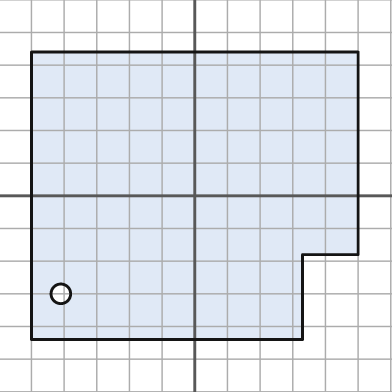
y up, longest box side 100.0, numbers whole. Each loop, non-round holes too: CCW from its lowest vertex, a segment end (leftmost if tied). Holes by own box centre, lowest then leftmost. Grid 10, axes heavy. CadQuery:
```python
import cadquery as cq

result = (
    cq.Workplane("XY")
    .moveTo(-50.0, -44.0)
    .lineTo(33.0, -44.0)
    .lineTo(33.0, -18.0)
    .lineTo(50.0, -18.0)
    .lineTo(50.0, 44.0)
    .lineTo(-50.0, 44.0)
    .close()
    .moveTo(-41.0, -30.0)
    .circle(3.0)
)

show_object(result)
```